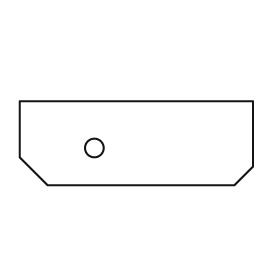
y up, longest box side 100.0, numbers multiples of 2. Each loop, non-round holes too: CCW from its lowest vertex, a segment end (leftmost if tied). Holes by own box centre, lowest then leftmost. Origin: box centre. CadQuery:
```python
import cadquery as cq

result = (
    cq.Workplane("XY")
    .moveTo(-38.0, -18.0)
    .lineTo(42.0, -18.0)
    .lineTo(50.0, -10.0)
    .lineTo(50.0, 18.0)
    .lineTo(-50.0, 18.0)
    .lineTo(-50.0, -6.0)
    .close()
    .moveTo(-18.0, -2.0)
    .circle(4.0)
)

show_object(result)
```